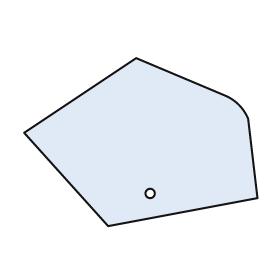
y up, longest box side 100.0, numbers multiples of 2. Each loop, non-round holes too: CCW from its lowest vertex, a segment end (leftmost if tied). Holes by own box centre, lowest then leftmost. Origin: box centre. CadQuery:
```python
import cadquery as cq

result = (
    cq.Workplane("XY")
    .moveTo(-14.0, -36.0)
    .lineTo(50.0, -24.0)
    .lineTo(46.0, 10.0)
    .threePointArc((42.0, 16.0), (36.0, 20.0))
    .lineTo(-2.0, 36.0)
    .lineTo(-50.0, 4.0)
    .close()
    .moveTo(4.0, -22.0)
    .circle(2.0)
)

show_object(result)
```